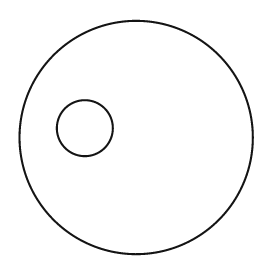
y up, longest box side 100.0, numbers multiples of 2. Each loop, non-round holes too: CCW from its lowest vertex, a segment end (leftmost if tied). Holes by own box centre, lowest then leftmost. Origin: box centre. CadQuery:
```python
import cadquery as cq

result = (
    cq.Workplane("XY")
    .moveTo(0.0, 0.0)
    .circle(50.0)
    .moveTo(-22.0, 4.0)
    .circle(12.0)
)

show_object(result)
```